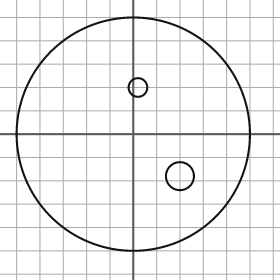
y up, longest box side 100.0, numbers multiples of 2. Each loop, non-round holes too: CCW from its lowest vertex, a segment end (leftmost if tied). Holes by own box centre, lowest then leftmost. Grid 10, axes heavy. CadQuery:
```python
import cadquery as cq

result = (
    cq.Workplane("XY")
    .moveTo(0.0, 0.0)
    .circle(50.0)
    .moveTo(20.0, -18.0)
    .circle(6.0)
    .moveTo(2.0, 20.0)
    .circle(4.0)
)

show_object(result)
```